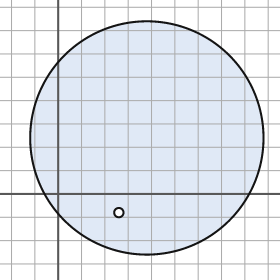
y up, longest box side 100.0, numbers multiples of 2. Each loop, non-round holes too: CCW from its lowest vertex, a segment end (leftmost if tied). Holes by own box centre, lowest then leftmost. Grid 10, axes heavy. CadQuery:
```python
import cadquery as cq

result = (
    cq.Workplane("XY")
    .moveTo(38.0, 24.0)
    .circle(50.0)
    .moveTo(26.0, -8.0)
    .circle(2.0)
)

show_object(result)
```